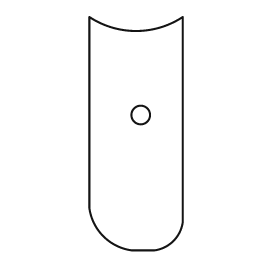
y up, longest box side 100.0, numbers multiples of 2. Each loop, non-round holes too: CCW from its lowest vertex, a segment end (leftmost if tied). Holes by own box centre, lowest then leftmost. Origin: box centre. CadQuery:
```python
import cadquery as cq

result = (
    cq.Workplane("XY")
    .moveTo(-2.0, -50.0)
    .lineTo(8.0, -50.0)
    .threePointArc((16.0, -46.0), (20.0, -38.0))
    .lineTo(20.0, 50.0)
    .threePointArc((0.0, 44.0), (-20.0, 50.0))
    .lineTo(-20.0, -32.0)
    .threePointArc((-14.0, -44.0), (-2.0, -50.0))
    .close()
    .moveTo(2.0, 8.0)
    .circle(4.0)
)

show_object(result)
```